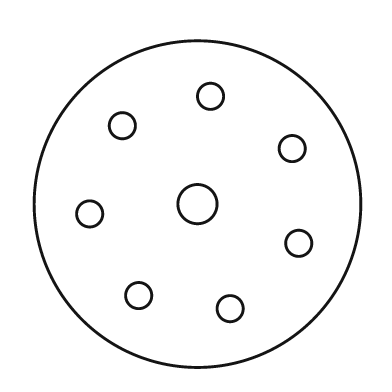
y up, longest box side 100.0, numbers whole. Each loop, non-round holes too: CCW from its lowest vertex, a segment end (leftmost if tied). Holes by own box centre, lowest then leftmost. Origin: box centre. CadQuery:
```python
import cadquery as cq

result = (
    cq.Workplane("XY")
    .moveTo(0.0, 0.0)
    .circle(50.0)
    .moveTo(10.0, -32.0)
    .circle(4.0)
    .moveTo(-18.0, -28.0)
    .circle(4.0)
    .moveTo(31.0, -12.0)
    .circle(4.0)
    .moveTo(-33.0, -3.0)
    .circle(4.0)
    .moveTo(0.0, 0.0)
    .circle(6.0)
    .moveTo(29.0, 17.0)
    .circle(4.0)
    .moveTo(-23.0, 24.0)
    .circle(4.0)
    .moveTo(4.0, 33.0)
    .circle(4.0)
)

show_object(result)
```